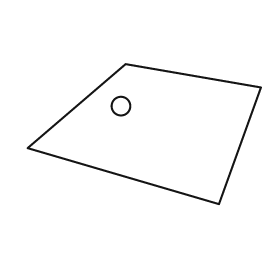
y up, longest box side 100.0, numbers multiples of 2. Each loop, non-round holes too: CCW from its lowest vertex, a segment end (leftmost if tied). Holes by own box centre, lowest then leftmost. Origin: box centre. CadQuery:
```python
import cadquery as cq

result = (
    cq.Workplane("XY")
    .moveTo(32.0, -30.0)
    .lineTo(50.0, 20.0)
    .lineTo(-8.0, 30.0)
    .lineTo(-50.0, -6.0)
    .close()
    .moveTo(-10.0, 12.0)
    .circle(4.0)
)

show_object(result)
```